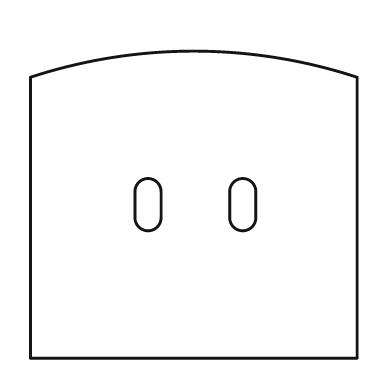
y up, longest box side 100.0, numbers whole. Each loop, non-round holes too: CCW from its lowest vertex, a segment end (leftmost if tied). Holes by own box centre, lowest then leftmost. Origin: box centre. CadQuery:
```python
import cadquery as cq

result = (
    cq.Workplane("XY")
    .moveTo(-50.0, -47.0)
    .lineTo(50.0, -47.0)
    .lineTo(50.0, 39.0)
    .threePointArc((0.0, 47.0), (-50.0, 39.0))
    .close()
    .moveTo(-18.0, -4.0)
    .threePointArc((-14.0, -8.0), (-10.0, -4.0))
    .lineTo(-10.0, 4.0)
    .threePointArc((-14.0, 8.0), (-18.0, 4.0))
    .close()
    .moveTo(11.0, -4.0)
    .threePointArc((15.0, -8.0), (19.0, -4.0))
    .lineTo(19.0, 4.0)
    .threePointArc((15.0, 8.0), (11.0, 4.0))
    .close()
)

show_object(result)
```